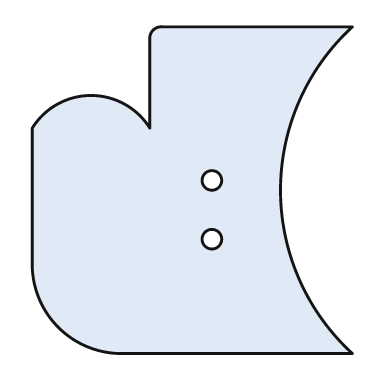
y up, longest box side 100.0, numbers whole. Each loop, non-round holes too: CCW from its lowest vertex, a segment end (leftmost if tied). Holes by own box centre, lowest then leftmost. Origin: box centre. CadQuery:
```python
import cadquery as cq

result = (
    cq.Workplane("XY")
    .moveTo(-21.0, -50.0)
    .lineTo(49.0, -50.0)
    .threePointArc((27.0, 0.0), (49.0, 50.0))
    .lineTo(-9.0, 50.0)
    .threePointArc((-12.0, 49.0), (-13.0, 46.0))
    .lineTo(-13.0, 19.0)
    .threePointArc((-31.0, 29.0), (-49.0, 19.0))
    .lineTo(-49.0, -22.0)
    .threePointArc((-41.0, -42.0), (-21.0, -50.0))
    .close()
    .moveTo(6.0, -15.0)
    .circle(3.0)
    .moveTo(6.0, 3.0)
    .circle(3.0)
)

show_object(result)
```